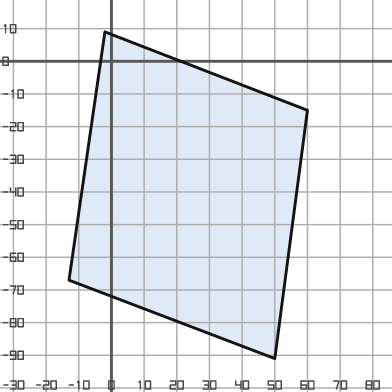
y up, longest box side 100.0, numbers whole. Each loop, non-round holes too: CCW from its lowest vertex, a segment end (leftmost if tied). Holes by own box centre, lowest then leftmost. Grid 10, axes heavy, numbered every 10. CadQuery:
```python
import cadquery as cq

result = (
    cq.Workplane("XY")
    .moveTo(50.0, -91.0)
    .lineTo(60.0, -15.0)
    .lineTo(-2.0, 9.0)
    .lineTo(-13.0, -67.0)
    .close()
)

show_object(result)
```